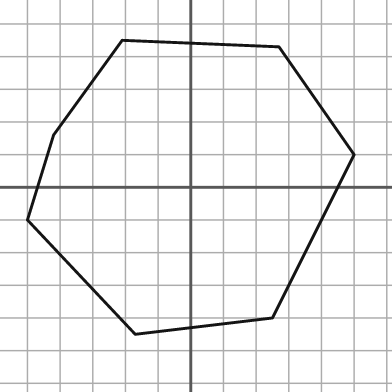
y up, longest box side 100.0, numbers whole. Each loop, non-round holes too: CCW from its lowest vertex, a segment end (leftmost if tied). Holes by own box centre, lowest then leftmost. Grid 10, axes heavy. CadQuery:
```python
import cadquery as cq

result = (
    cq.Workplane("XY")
    .moveTo(-17.0, -45.0)
    .lineTo(25.0, -40.0)
    .lineTo(50.0, 10.0)
    .lineTo(27.0, 43.0)
    .lineTo(-21.0, 45.0)
    .lineTo(-42.0, 16.0)
    .lineTo(-50.0, -10.0)
    .close()
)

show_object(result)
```